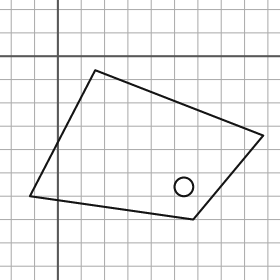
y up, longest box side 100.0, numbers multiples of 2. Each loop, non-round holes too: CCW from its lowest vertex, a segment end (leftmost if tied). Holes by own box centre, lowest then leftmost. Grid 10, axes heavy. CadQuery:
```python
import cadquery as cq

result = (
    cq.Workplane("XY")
    .moveTo(58.0, -70.0)
    .lineTo(88.0, -34.0)
    .lineTo(16.0, -6.0)
    .lineTo(-12.0, -60.0)
    .close()
    .moveTo(54.0, -56.0)
    .circle(4.0)
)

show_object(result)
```